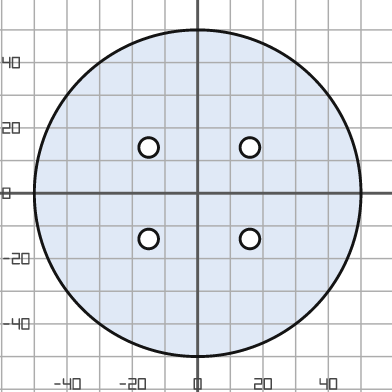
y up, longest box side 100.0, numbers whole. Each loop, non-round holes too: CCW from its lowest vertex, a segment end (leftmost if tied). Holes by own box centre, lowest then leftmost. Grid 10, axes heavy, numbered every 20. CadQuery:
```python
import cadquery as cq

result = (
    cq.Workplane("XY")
    .moveTo(0.0, 0.0)
    .circle(50.0)
    .moveTo(-15.0, -14.0)
    .circle(3.0)
    .moveTo(16.0, -14.0)
    .circle(3.0)
    .moveTo(-15.0, 14.0)
    .circle(3.0)
    .moveTo(16.0, 14.0)
    .circle(3.0)
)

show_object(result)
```